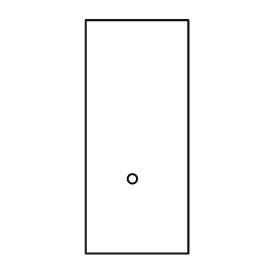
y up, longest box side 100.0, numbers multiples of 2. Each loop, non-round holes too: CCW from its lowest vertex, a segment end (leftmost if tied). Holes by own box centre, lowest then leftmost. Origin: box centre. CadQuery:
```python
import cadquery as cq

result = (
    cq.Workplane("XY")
    .moveTo(-22.0, -50.0)
    .lineTo(22.0, -50.0)
    .lineTo(22.0, 50.0)
    .lineTo(-22.0, 50.0)
    .close()
    .moveTo(-2.0, -18.0)
    .circle(2.0)
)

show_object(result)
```